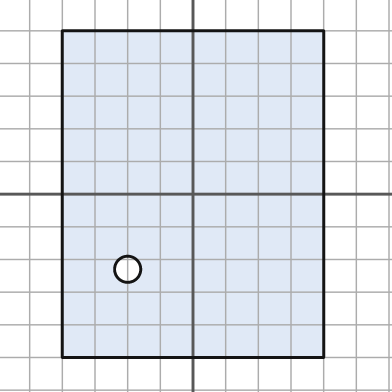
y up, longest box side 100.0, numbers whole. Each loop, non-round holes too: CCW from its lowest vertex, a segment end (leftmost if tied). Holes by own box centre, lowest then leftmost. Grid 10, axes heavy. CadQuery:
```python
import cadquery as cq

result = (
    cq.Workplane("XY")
    .moveTo(-40.0, -50.0)
    .lineTo(40.0, -50.0)
    .lineTo(40.0, 50.0)
    .lineTo(-40.0, 50.0)
    .close()
    .moveTo(-20.0, -23.0)
    .circle(4.0)
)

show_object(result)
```